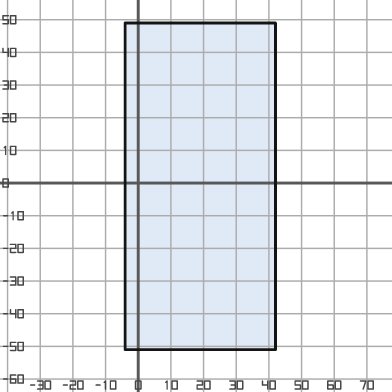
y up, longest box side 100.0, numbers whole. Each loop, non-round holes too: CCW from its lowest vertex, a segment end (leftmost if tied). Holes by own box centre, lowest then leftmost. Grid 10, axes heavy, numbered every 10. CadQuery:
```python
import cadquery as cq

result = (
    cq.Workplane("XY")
    .moveTo(-4.0, -51.0)
    .lineTo(42.0, -51.0)
    .lineTo(42.0, 49.0)
    .lineTo(-4.0, 49.0)
    .close()
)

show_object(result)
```